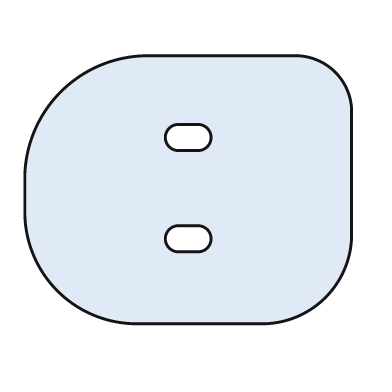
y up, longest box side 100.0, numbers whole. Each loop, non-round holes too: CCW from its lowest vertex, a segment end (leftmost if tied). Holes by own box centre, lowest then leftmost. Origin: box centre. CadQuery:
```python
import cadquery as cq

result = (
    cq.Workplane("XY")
    .moveTo(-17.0, -41.0)
    .lineTo(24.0, -41.0)
    .threePointArc((42.0, -33.0), (50.0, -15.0))
    .lineTo(50.0, 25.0)
    .threePointArc((45.0, 36.0), (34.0, 41.0))
    .lineTo(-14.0, 41.0)
    .threePointArc((-39.0, 30.0), (-50.0, 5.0))
    .lineTo(-50.0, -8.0)
    .threePointArc((-40.0, -31.0), (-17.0, -41.0))
    .close()
    .moveTo(-3.0, -19.0)
    .lineTo(3.0, -19.0)
    .threePointArc((7.0, -15.0), (3.0, -11.0))
    .lineTo(-3.0, -11.0)
    .threePointArc((-7.0, -15.0), (-3.0, -19.0))
    .close()
    .moveTo(-3.0, 12.0)
    .lineTo(3.0, 12.0)
    .threePointArc((7.0, 16.0), (3.0, 20.0))
    .lineTo(-3.0, 20.0)
    .threePointArc((-7.0, 16.0), (-3.0, 12.0))
    .close()
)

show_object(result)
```